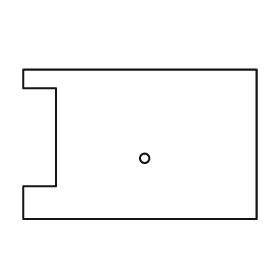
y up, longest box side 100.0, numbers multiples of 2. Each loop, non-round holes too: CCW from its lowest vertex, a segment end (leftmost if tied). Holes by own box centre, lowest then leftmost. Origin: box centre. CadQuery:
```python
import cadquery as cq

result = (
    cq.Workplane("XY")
    .moveTo(-50.0, -32.0)
    .lineTo(50.0, -32.0)
    .lineTo(50.0, 32.0)
    .lineTo(-50.0, 32.0)
    .lineTo(-50.0, 24.0)
    .lineTo(-36.0, 24.0)
    .lineTo(-36.0, -18.0)
    .lineTo(-50.0, -18.0)
    .close()
    .moveTo(2.0, -6.0)
    .circle(2.0)
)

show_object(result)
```